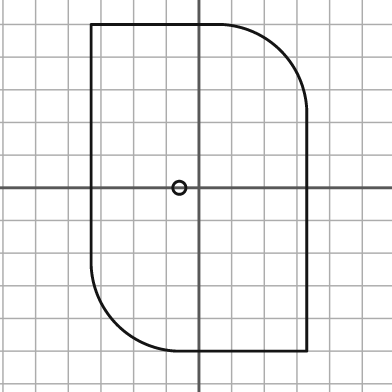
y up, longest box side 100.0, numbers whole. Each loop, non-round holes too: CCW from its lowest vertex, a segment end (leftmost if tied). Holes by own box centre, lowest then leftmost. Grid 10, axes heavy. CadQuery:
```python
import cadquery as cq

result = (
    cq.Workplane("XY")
    .moveTo(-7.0, -50.0)
    .lineTo(33.0, -50.0)
    .lineTo(33.0, 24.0)
    .threePointArc((25.0, 42.0), (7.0, 50.0))
    .lineTo(-33.0, 50.0)
    .lineTo(-33.0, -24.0)
    .threePointArc((-25.0, -42.0), (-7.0, -50.0))
    .close()
    .moveTo(-6.0, 0.0)
    .circle(2.0)
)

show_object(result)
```